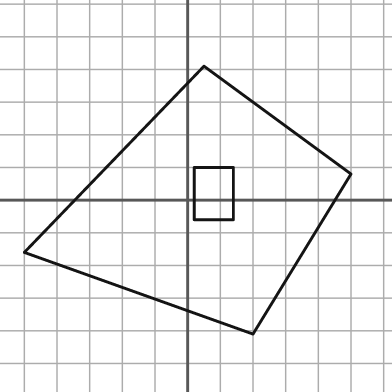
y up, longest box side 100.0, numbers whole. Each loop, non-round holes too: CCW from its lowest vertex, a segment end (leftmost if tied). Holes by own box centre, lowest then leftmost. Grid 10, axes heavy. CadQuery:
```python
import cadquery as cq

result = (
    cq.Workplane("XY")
    .moveTo(20.0, -41.0)
    .lineTo(50.0, 8.0)
    .lineTo(5.0, 41.0)
    .lineTo(-50.0, -16.0)
    .close()
    .moveTo(2.0, -6.0)
    .lineTo(14.0, -6.0)
    .lineTo(14.0, 10.0)
    .lineTo(2.0, 10.0)
    .close()
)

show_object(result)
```